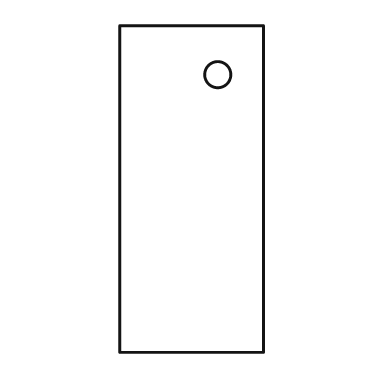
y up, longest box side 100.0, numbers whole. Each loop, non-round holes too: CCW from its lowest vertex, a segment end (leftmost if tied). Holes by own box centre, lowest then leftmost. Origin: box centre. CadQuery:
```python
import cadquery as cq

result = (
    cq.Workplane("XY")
    .moveTo(-22.0, -50.0)
    .lineTo(22.0, -50.0)
    .lineTo(22.0, 50.0)
    .lineTo(-22.0, 50.0)
    .close()
    .moveTo(8.0, 35.0)
    .circle(4.0)
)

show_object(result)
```